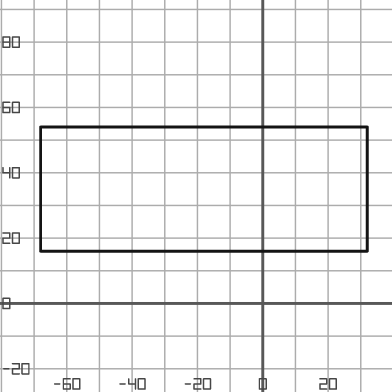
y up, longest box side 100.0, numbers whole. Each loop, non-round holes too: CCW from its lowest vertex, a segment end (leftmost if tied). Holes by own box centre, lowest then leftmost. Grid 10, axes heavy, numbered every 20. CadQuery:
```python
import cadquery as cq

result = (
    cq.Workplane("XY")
    .moveTo(-68.0, 16.0)
    .lineTo(32.0, 16.0)
    .lineTo(32.0, 54.0)
    .lineTo(-68.0, 54.0)
    .close()
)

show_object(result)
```